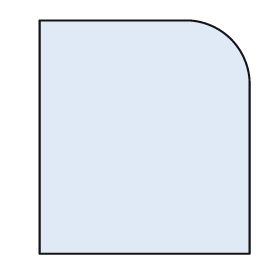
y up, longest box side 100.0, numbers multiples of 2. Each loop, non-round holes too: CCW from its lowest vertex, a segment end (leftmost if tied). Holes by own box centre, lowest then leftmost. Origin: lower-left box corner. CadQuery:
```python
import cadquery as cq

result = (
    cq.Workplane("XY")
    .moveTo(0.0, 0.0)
    .lineTo(90.0, 0.0)
    .lineTo(90.0, 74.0)
    .threePointArc((82.0, 92.0), (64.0, 100.0))
    .lineTo(0.0, 100.0)
    .close()
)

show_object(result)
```